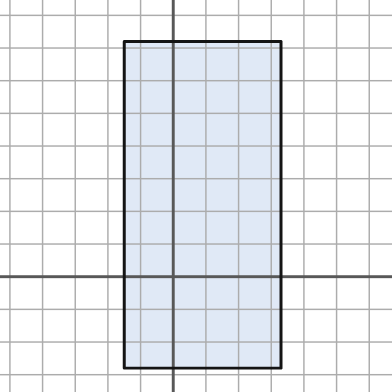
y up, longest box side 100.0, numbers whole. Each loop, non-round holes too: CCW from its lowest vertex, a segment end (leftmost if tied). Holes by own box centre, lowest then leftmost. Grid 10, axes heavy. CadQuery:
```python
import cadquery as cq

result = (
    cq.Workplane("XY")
    .moveTo(-15.0, -28.0)
    .lineTo(33.0, -28.0)
    .lineTo(33.0, 72.0)
    .lineTo(-15.0, 72.0)
    .close()
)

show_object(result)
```